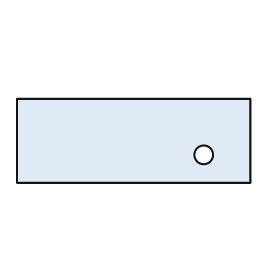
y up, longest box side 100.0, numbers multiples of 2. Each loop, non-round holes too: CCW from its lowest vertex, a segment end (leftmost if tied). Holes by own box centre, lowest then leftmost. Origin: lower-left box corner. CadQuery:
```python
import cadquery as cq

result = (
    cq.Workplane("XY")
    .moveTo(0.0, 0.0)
    .lineTo(100.0, 0.0)
    .lineTo(100.0, 36.0)
    .lineTo(0.0, 36.0)
    .close()
    .moveTo(80.0, 12.0)
    .circle(4.0)
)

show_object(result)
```